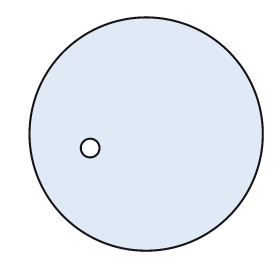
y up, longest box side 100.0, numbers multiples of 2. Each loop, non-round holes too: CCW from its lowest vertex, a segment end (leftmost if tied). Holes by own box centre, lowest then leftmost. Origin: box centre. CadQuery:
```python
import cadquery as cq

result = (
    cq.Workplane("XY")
    .moveTo(0.0, 0.0)
    .circle(50.0)
    .moveTo(-24.0, -6.0)
    .circle(4.0)
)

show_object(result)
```